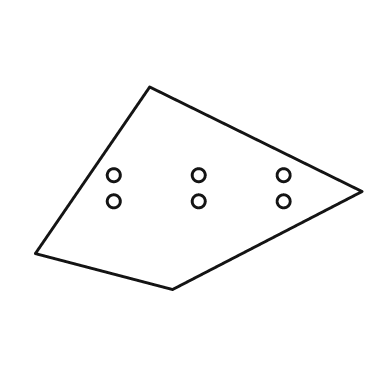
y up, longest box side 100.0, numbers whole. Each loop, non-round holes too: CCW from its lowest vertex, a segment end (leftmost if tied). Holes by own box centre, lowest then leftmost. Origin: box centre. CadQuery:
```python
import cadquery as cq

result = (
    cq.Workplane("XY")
    .moveTo(-8.0, -31.0)
    .lineTo(50.0, -1.0)
    .lineTo(-15.0, 31.0)
    .lineTo(-50.0, -20.0)
    .close()
    .moveTo(-26.0, -4.0)
    .circle(2.0)
    .moveTo(0.0, -4.0)
    .circle(2.0)
    .moveTo(26.0, -4.0)
    .circle(2.0)
    .moveTo(-26.0, 4.0)
    .circle(2.0)
    .moveTo(0.0, 4.0)
    .circle(2.0)
    .moveTo(26.0, 4.0)
    .circle(2.0)
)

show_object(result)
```